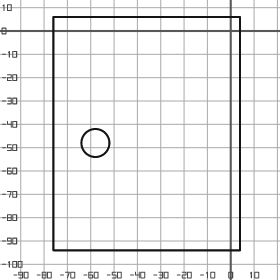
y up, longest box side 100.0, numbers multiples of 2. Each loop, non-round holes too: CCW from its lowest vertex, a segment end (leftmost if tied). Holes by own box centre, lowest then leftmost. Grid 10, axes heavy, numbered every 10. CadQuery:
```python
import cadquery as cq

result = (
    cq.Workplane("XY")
    .moveTo(-76.0, -94.0)
    .lineTo(4.0, -94.0)
    .lineTo(4.0, 6.0)
    .lineTo(-76.0, 6.0)
    .close()
    .moveTo(-58.0, -48.0)
    .circle(6.0)
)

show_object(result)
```